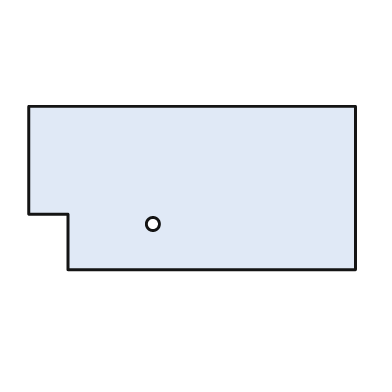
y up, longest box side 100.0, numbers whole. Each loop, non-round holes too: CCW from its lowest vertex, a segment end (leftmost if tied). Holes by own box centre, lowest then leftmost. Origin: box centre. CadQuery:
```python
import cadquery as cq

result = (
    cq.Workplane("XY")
    .moveTo(-38.0, -25.0)
    .lineTo(50.0, -25.0)
    .lineTo(50.0, 25.0)
    .lineTo(-50.0, 25.0)
    .lineTo(-50.0, -8.0)
    .lineTo(-38.0, -8.0)
    .close()
    .moveTo(-12.0, -11.0)
    .circle(2.0)
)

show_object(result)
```